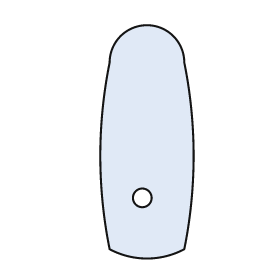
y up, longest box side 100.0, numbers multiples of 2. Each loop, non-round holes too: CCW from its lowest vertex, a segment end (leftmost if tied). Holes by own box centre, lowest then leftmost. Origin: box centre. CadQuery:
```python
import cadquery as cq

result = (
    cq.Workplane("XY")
    .moveTo(-16.0, -46.0)
    .threePointArc((0.0, -50.0), (16.0, -46.0))
    .threePointArc((20.0, -6.0), (16.0, 34.0))
    .threePointArc((0.0, 50.0), (-16.0, 34.0))
    .threePointArc((-20.0, -6.0), (-16.0, -46.0))
    .close()
    .moveTo(-2.0, -24.0)
    .circle(4.0)
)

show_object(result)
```